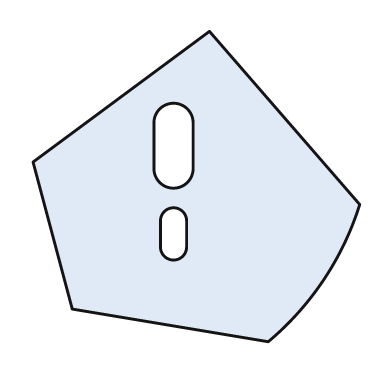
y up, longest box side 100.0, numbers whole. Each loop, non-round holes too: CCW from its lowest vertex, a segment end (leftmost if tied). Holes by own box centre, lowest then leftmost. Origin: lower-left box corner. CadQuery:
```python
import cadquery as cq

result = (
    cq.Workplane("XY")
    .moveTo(72.0, 0.0)
    .threePointArc((89.0, 19.0), (100.0, 42.0))
    .lineTo(54.0, 95.0)
    .lineTo(0.0, 55.0)
    .lineTo(12.0, 10.0)
    .close()
    .moveTo(39.0, 29.0)
    .threePointArc((43.0, 25.0), (47.0, 29.0))
    .lineTo(47.0, 37.0)
    .threePointArc((43.0, 41.0), (39.0, 37.0))
    .close()
    .moveTo(37.0, 53.0)
    .threePointArc((43.0, 47.0), (49.0, 53.0))
    .lineTo(49.0, 67.0)
    .threePointArc((43.0, 73.0), (37.0, 67.0))
    .close()
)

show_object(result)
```